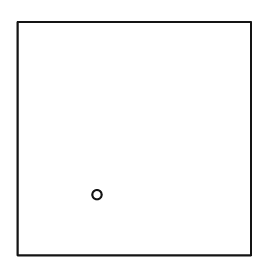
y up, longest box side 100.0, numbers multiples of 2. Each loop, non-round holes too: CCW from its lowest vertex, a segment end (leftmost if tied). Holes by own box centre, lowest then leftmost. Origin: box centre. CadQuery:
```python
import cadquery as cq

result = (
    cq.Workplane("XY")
    .moveTo(-50.0, -50.0)
    .lineTo(50.0, -50.0)
    .lineTo(50.0, 50.0)
    .lineTo(-50.0, 50.0)
    .close()
    .moveTo(-16.0, -24.0)
    .circle(2.0)
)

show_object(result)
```